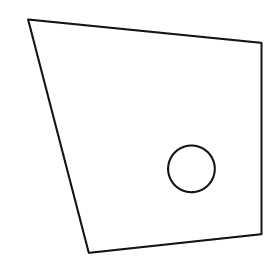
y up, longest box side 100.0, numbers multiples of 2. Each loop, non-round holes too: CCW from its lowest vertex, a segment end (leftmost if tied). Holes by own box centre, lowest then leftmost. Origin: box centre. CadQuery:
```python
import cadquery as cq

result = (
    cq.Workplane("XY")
    .moveTo(-24.0, -50.0)
    .lineTo(50.0, -42.0)
    .lineTo(50.0, 40.0)
    .lineTo(-50.0, 50.0)
    .close()
    .moveTo(20.0, -14.0)
    .circle(10.0)
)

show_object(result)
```